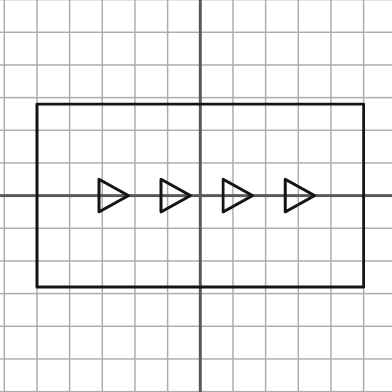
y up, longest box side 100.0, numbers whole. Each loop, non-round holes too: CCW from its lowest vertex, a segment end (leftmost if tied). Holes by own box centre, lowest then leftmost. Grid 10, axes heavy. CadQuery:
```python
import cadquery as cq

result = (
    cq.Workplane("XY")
    .moveTo(-50.0, -28.0)
    .lineTo(50.0, -28.0)
    .lineTo(50.0, 28.0)
    .lineTo(-50.0, 28.0)
    .close()
    .moveTo(-31.0, -5.0)
    .lineTo(-22.0, 0.0)
    .lineTo(-31.0, 5.0)
    .close()
    .moveTo(-12.0, -5.0)
    .lineTo(-3.0, 0.0)
    .lineTo(-12.0, 5.0)
    .close()
    .moveTo(7.0, -5.0)
    .lineTo(16.0, 0.0)
    .lineTo(7.0, 5.0)
    .close()
    .moveTo(26.0, -5.0)
    .lineTo(35.0, 0.0)
    .lineTo(26.0, 5.0)
    .close()
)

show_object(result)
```